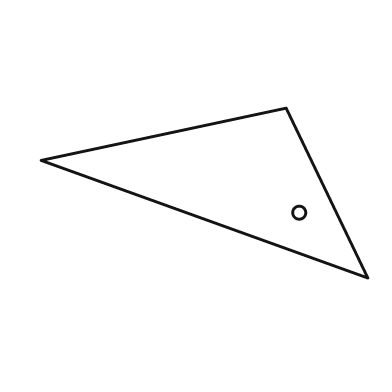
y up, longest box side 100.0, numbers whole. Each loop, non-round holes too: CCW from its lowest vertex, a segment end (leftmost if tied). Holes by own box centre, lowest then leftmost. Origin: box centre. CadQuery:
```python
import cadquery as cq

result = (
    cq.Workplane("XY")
    .moveTo(50.0, -26.0)
    .lineTo(25.0, 26.0)
    .lineTo(-50.0, 10.0)
    .close()
    .moveTo(29.0, -6.0)
    .circle(2.0)
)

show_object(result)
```